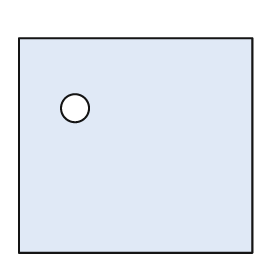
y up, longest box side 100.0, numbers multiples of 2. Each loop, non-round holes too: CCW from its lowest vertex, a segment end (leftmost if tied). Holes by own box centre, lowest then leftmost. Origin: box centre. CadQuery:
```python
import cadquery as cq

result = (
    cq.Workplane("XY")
    .moveTo(-50.0, -46.0)
    .lineTo(50.0, -46.0)
    .lineTo(50.0, 46.0)
    .lineTo(-50.0, 46.0)
    .close()
    .moveTo(-26.0, 16.0)
    .circle(6.0)
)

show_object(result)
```